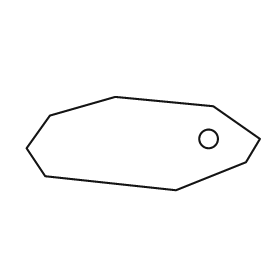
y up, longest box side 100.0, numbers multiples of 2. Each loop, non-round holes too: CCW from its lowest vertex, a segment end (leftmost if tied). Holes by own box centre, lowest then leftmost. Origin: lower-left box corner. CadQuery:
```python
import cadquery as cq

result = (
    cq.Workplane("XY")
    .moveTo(64.0, 0.0)
    .lineTo(94.0, 12.0)
    .lineTo(100.0, 22.0)
    .lineTo(80.0, 36.0)
    .lineTo(38.0, 40.0)
    .lineTo(10.0, 32.0)
    .lineTo(0.0, 18.0)
    .lineTo(8.0, 6.0)
    .close()
    .moveTo(78.0, 22.0)
    .circle(4.0)
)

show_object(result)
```